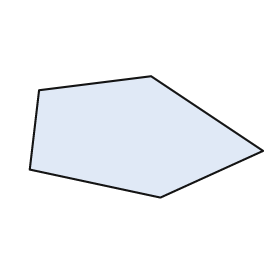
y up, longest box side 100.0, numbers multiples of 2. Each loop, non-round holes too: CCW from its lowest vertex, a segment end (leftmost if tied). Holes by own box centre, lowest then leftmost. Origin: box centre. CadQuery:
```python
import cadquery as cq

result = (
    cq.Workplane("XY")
    .moveTo(6.0, -26.0)
    .lineTo(50.0, -6.0)
    .lineTo(2.0, 26.0)
    .lineTo(-46.0, 20.0)
    .lineTo(-50.0, -14.0)
    .close()
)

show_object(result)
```